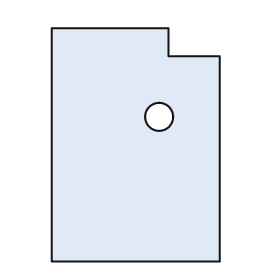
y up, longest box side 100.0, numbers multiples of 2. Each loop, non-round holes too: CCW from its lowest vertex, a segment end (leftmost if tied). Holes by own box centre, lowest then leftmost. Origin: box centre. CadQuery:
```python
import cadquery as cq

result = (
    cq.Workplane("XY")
    .moveTo(-36.0, -50.0)
    .lineTo(36.0, -50.0)
    .lineTo(36.0, 38.0)
    .lineTo(14.0, 38.0)
    .lineTo(14.0, 50.0)
    .lineTo(-36.0, 50.0)
    .close()
    .moveTo(10.0, 12.0)
    .circle(6.0)
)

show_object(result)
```